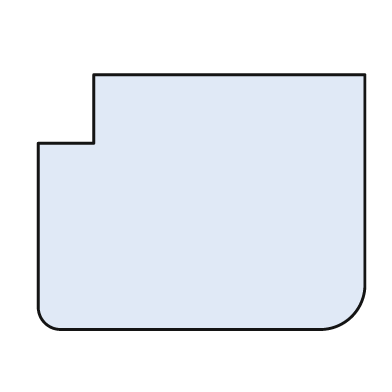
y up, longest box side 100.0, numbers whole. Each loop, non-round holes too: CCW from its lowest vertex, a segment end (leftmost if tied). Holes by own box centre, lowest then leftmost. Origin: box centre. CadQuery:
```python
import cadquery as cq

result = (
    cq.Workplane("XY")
    .moveTo(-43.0, -39.0)
    .lineTo(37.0, -39.0)
    .threePointArc((46.0, -35.0), (50.0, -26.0))
    .lineTo(50.0, 39.0)
    .lineTo(-33.0, 39.0)
    .lineTo(-33.0, 18.0)
    .lineTo(-50.0, 18.0)
    .lineTo(-50.0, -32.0)
    .threePointArc((-48.0, -37.0), (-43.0, -39.0))
    .close()
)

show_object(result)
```